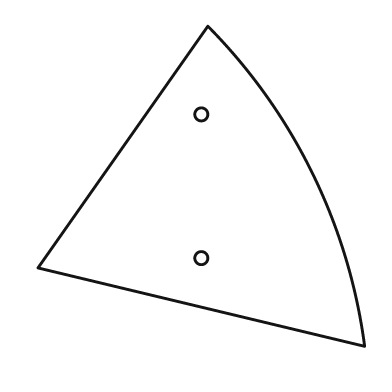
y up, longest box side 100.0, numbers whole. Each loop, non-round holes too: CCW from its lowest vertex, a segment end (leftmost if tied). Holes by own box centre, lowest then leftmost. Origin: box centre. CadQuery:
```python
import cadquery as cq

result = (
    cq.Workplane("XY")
    .moveTo(50.0, -49.0)
    .threePointArc((34.0, 4.0), (2.0, 49.0))
    .lineTo(-50.0, -25.0)
    .close()
    .moveTo(0.0, -22.0)
    .circle(2.0)
    .moveTo(0.0, 22.0)
    .circle(2.0)
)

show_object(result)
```